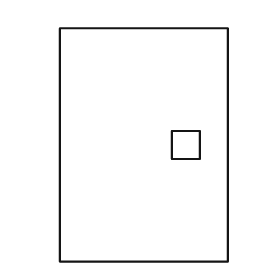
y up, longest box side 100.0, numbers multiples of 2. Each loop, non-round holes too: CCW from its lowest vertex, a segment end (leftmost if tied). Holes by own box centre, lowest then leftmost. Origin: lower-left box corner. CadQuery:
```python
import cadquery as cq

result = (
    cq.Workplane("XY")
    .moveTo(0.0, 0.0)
    .lineTo(72.0, 0.0)
    .lineTo(72.0, 100.0)
    .lineTo(0.0, 100.0)
    .close()
    .moveTo(48.0, 44.0)
    .lineTo(60.0, 44.0)
    .lineTo(60.0, 56.0)
    .lineTo(48.0, 56.0)
    .close()
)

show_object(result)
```